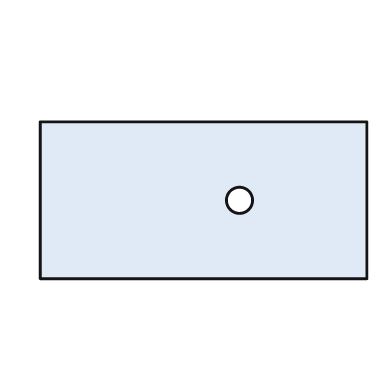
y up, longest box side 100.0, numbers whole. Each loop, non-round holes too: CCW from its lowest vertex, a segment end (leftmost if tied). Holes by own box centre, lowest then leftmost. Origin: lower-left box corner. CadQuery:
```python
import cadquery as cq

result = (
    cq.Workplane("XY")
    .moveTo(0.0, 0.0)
    .lineTo(100.0, 0.0)
    .lineTo(100.0, 48.0)
    .lineTo(0.0, 48.0)
    .close()
    .moveTo(61.0, 24.0)
    .circle(4.0)
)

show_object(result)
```